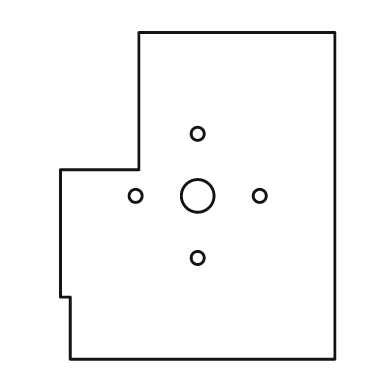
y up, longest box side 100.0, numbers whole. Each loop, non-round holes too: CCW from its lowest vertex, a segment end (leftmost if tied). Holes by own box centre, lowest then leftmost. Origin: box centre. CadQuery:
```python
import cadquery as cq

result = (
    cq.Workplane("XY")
    .moveTo(-39.0, -50.0)
    .lineTo(42.0, -50.0)
    .lineTo(42.0, 50.0)
    .lineTo(-18.0, 50.0)
    .lineTo(-18.0, 8.0)
    .lineTo(-42.0, 8.0)
    .lineTo(-42.0, -31.0)
    .lineTo(-39.0, -31.0)
    .close()
    .moveTo(0.0, -19.0)
    .circle(2.0)
    .moveTo(-19.0, 0.0)
    .circle(2.0)
    .moveTo(0.0, 0.0)
    .circle(5.0)
    .moveTo(19.0, 0.0)
    .circle(2.0)
    .moveTo(0.0, 19.0)
    .circle(2.0)
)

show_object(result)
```